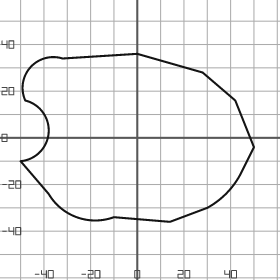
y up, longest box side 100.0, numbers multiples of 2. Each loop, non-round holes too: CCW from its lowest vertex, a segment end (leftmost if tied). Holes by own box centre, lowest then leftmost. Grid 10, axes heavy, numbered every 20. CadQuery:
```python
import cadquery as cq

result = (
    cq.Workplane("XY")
    .moveTo(14.0, -36.0)
    .lineTo(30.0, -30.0)
    .threePointArc((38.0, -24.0), (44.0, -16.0))
    .lineTo(50.0, -4.0)
    .lineTo(42.0, 16.0)
    .lineTo(28.0, 28.0)
    .lineTo(0.0, 36.0)
    .lineTo(-32.0, 34.0)
    .threePointArc((-46.0, 30.0), (-48.0, 16.0))
    .threePointArc((-38.0, 2.0), (-50.0, -10.0))
    .lineTo(-38.0, -24.0)
    .threePointArc((-26.0, -34.0), (-10.0, -34.0))
    .close()
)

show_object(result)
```